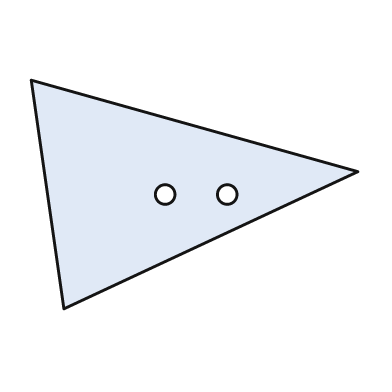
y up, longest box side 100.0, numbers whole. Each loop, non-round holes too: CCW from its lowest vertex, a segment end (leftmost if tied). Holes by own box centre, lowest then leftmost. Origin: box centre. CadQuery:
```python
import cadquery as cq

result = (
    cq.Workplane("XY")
    .moveTo(-40.0, -35.0)
    .lineTo(50.0, 7.0)
    .lineTo(-50.0, 35.0)
    .close()
    .moveTo(-9.0, 0.0)
    .circle(3.0)
    .moveTo(10.0, 0.0)
    .circle(3.0)
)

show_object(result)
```